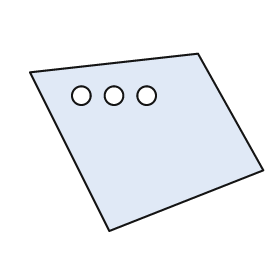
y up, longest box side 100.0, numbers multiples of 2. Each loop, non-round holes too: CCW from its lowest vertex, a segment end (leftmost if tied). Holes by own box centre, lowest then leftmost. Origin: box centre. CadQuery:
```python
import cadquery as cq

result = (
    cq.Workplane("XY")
    .moveTo(-16.0, -38.0)
    .lineTo(50.0, -12.0)
    .lineTo(22.0, 38.0)
    .lineTo(-50.0, 30.0)
    .close()
    .moveTo(-28.0, 20.0)
    .circle(4.0)
    .moveTo(-14.0, 20.0)
    .circle(4.0)
    .moveTo(0.0, 20.0)
    .circle(4.0)
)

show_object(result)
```